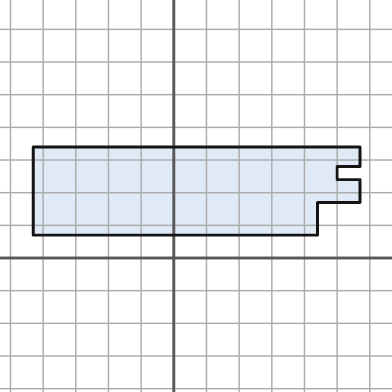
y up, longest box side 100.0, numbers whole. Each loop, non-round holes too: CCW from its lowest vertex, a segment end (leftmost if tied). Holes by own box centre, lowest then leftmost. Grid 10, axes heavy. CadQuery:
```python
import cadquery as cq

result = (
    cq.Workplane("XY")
    .moveTo(-43.0, 7.0)
    .lineTo(44.0, 7.0)
    .lineTo(44.0, 17.0)
    .lineTo(57.0, 17.0)
    .lineTo(57.0, 24.0)
    .lineTo(50.0, 24.0)
    .lineTo(50.0, 28.0)
    .lineTo(57.0, 28.0)
    .lineTo(57.0, 34.0)
    .lineTo(-43.0, 34.0)
    .close()
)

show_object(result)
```